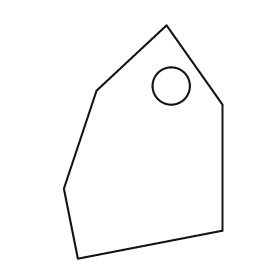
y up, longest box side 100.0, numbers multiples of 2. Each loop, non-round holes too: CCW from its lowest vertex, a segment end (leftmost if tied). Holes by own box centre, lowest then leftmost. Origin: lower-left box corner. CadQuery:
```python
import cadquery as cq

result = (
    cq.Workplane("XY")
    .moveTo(6.0, 0.0)
    .lineTo(68.0, 12.0)
    .lineTo(68.0, 66.0)
    .lineTo(44.0, 100.0)
    .lineTo(14.0, 72.0)
    .lineTo(0.0, 30.0)
    .close()
    .moveTo(46.0, 74.0)
    .circle(8.0)
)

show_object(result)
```